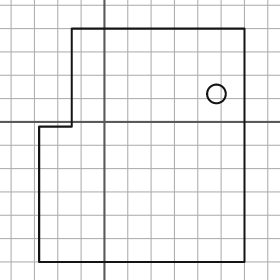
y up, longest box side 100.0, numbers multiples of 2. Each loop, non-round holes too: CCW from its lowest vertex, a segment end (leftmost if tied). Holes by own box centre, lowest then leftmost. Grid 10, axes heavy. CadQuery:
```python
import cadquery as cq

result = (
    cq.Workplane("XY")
    .moveTo(-28.0, -60.0)
    .lineTo(60.0, -60.0)
    .lineTo(60.0, 40.0)
    .lineTo(-14.0, 40.0)
    .lineTo(-14.0, -2.0)
    .lineTo(-28.0, -2.0)
    .close()
    .moveTo(48.0, 12.0)
    .circle(4.0)
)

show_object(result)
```